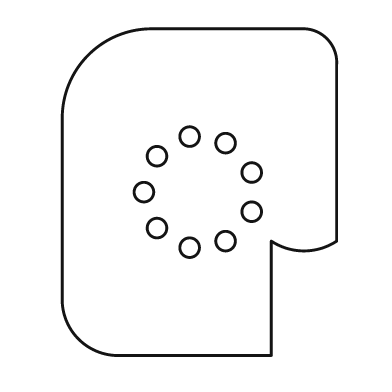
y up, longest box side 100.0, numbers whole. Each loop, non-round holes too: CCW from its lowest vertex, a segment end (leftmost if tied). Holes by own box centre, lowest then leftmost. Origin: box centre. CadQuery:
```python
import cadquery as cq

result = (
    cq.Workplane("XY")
    .moveTo(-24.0, -50.0)
    .lineTo(22.0, -50.0)
    .lineTo(22.0, -15.0)
    .threePointArc((32.0, -18.0), (42.0, -15.0))
    .lineTo(42.0, 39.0)
    .threePointArc((39.0, 47.0), (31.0, 50.0))
    .lineTo(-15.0, 50.0)
    .threePointArc((-34.0, 42.0), (-42.0, 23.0))
    .lineTo(-42.0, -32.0)
    .threePointArc((-37.0, -45.0), (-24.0, -50.0))
    .close()
    .moveTo(-3.0, -17.0)
    .circle(3.0)
    .moveTo(8.0, -15.0)
    .circle(3.0)
    .moveTo(-13.0, -11.0)
    .circle(3.0)
    .moveTo(16.0, -6.0)
    .circle(3.0)
    .moveTo(-17.0, 0.0)
    .circle(3.0)
    .moveTo(16.0, 6.0)
    .circle(3.0)
    .moveTo(-13.0, 11.0)
    .circle(3.0)
    .moveTo(8.0, 15.0)
    .circle(3.0)
    .moveTo(-3.0, 17.0)
    .circle(3.0)
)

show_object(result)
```